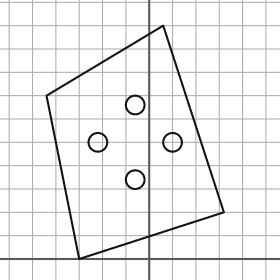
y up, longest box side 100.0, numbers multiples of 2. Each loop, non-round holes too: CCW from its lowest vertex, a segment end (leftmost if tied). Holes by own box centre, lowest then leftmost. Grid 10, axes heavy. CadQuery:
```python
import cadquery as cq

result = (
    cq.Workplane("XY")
    .moveTo(-30.0, 0.0)
    .lineTo(32.0, 20.0)
    .lineTo(6.0, 100.0)
    .lineTo(-44.0, 70.0)
    .close()
    .moveTo(-6.0, 34.0)
    .circle(4.0)
    .moveTo(-22.0, 50.0)
    .circle(4.0)
    .moveTo(10.0, 50.0)
    .circle(4.0)
    .moveTo(-6.0, 66.0)
    .circle(4.0)
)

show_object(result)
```